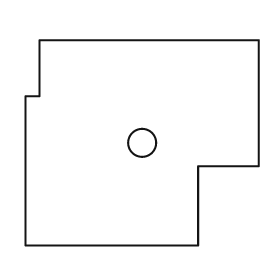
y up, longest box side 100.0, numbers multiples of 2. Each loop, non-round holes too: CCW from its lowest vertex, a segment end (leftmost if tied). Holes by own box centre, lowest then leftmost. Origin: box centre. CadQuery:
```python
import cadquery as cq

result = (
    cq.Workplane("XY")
    .moveTo(-50.0, -44.0)
    .lineTo(24.0, -44.0)
    .lineTo(24.0, -10.0)
    .lineTo(50.0, -10.0)
    .lineTo(50.0, 44.0)
    .lineTo(-44.0, 44.0)
    .lineTo(-44.0, 20.0)
    .lineTo(-50.0, 20.0)
    .close()
    .moveTo(0.0, 0.0)
    .circle(6.0)
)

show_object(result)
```